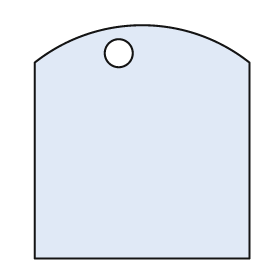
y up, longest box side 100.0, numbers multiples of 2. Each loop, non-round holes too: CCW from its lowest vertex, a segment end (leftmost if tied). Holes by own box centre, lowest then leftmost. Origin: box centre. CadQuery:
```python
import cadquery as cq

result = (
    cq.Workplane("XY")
    .moveTo(-46.0, -50.0)
    .lineTo(46.0, -50.0)
    .lineTo(46.0, 34.0)
    .threePointArc((0.0, 50.0), (-46.0, 34.0))
    .close()
    .moveTo(-10.0, 38.0)
    .circle(6.0)
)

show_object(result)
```